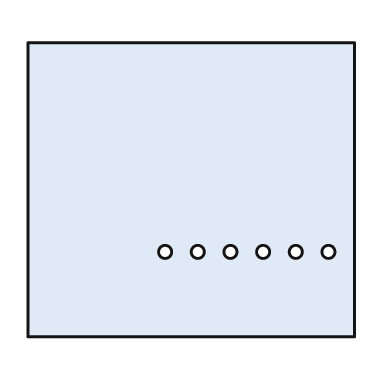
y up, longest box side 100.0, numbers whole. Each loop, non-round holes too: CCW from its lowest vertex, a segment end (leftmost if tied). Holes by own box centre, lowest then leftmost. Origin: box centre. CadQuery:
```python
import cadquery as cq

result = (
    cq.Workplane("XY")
    .moveTo(-50.0, -45.0)
    .lineTo(50.0, -45.0)
    .lineTo(50.0, 45.0)
    .lineTo(-50.0, 45.0)
    .close()
    .moveTo(-8.0, -19.0)
    .circle(2.0)
    .moveTo(2.0, -19.0)
    .circle(2.0)
    .moveTo(12.0, -19.0)
    .circle(2.0)
    .moveTo(22.0, -19.0)
    .circle(2.0)
    .moveTo(32.0, -19.0)
    .circle(2.0)
    .moveTo(42.0, -19.0)
    .circle(2.0)
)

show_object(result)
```